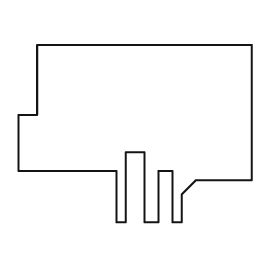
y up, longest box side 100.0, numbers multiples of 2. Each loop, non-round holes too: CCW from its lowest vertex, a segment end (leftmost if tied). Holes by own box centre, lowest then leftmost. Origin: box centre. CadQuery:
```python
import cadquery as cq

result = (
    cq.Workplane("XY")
    .moveTo(-8.0, -38.0)
    .lineTo(-4.0, -38.0)
    .lineTo(-4.0, -8.0)
    .lineTo(4.0, -8.0)
    .lineTo(4.0, -38.0)
    .lineTo(10.0, -38.0)
    .lineTo(10.0, -16.0)
    .lineTo(16.0, -16.0)
    .lineTo(16.0, -38.0)
    .lineTo(20.0, -38.0)
    .lineTo(20.0, -26.0)
    .lineTo(26.0, -20.0)
    .lineTo(50.0, -20.0)
    .lineTo(50.0, 38.0)
    .lineTo(-42.0, 38.0)
    .lineTo(-42.0, 8.0)
    .lineTo(-50.0, 8.0)
    .lineTo(-50.0, -16.0)
    .lineTo(-8.0, -16.0)
    .close()
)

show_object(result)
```